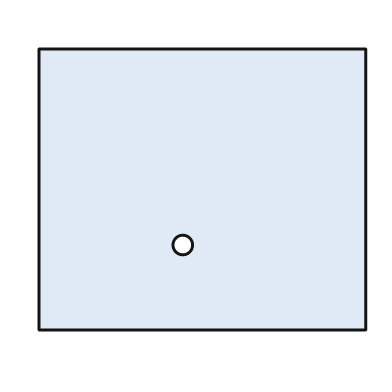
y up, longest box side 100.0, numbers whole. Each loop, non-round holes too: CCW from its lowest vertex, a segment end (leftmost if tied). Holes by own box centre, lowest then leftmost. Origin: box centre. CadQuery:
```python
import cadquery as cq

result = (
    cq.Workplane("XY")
    .moveTo(-50.0, -43.0)
    .lineTo(50.0, -43.0)
    .lineTo(50.0, 43.0)
    .lineTo(-50.0, 43.0)
    .close()
    .moveTo(-6.0, -17.0)
    .circle(3.0)
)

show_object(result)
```